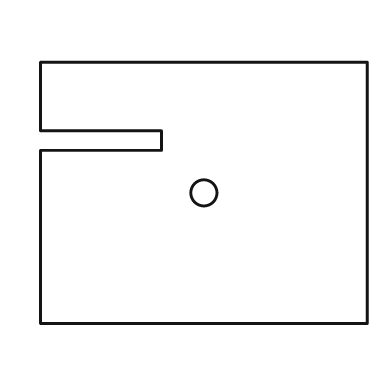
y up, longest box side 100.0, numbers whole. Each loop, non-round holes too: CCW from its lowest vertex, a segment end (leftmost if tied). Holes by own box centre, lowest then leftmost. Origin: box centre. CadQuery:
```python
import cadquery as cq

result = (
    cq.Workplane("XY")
    .moveTo(-50.0, -40.0)
    .lineTo(50.0, -40.0)
    .lineTo(50.0, 40.0)
    .lineTo(-50.0, 40.0)
    .lineTo(-50.0, 19.0)
    .lineTo(-13.0, 19.0)
    .lineTo(-13.0, 13.0)
    .lineTo(-50.0, 13.0)
    .close()
    .moveTo(0.0, 0.0)
    .circle(4.0)
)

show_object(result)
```